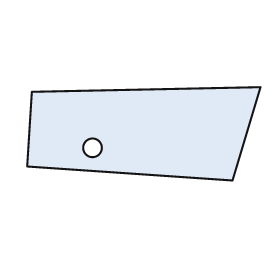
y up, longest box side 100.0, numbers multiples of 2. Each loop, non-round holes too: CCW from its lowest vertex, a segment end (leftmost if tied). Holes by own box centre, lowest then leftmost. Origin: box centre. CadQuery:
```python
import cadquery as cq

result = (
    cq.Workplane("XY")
    .moveTo(38.0, -20.0)
    .lineTo(50.0, 20.0)
    .lineTo(-48.0, 18.0)
    .lineTo(-50.0, -14.0)
    .close()
    .moveTo(-22.0, -6.0)
    .circle(4.0)
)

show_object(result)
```